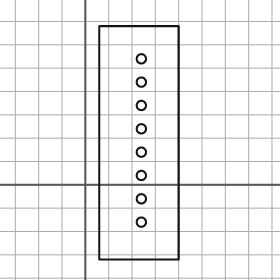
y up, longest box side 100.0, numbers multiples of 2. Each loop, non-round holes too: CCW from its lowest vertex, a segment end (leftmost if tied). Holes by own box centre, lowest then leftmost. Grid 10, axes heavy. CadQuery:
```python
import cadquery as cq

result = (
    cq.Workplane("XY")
    .moveTo(6.0, -32.0)
    .lineTo(40.0, -32.0)
    .lineTo(40.0, 68.0)
    .lineTo(6.0, 68.0)
    .close()
    .moveTo(24.0, -16.0)
    .circle(2.0)
    .moveTo(24.0, -6.0)
    .circle(2.0)
    .moveTo(24.0, 4.0)
    .circle(2.0)
    .moveTo(24.0, 14.0)
    .circle(2.0)
    .moveTo(24.0, 24.0)
    .circle(2.0)
    .moveTo(24.0, 34.0)
    .circle(2.0)
    .moveTo(24.0, 44.0)
    .circle(2.0)
    .moveTo(24.0, 54.0)
    .circle(2.0)
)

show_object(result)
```